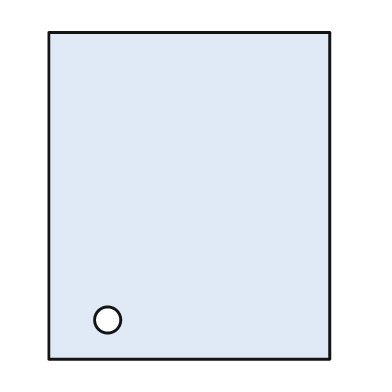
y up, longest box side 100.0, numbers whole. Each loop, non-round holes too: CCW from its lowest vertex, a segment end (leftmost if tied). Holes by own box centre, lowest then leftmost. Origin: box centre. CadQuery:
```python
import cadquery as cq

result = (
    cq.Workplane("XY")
    .moveTo(-43.0, -50.0)
    .lineTo(43.0, -50.0)
    .lineTo(43.0, 50.0)
    .lineTo(-43.0, 50.0)
    .close()
    .moveTo(-25.0, -38.0)
    .circle(4.0)
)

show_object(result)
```